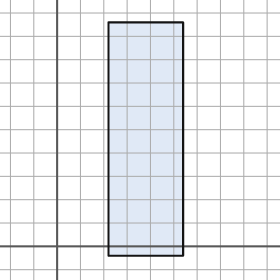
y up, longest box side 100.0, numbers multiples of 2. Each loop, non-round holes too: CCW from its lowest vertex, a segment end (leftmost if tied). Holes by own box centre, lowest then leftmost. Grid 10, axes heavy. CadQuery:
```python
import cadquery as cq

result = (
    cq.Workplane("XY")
    .moveTo(22.0, -4.0)
    .lineTo(54.0, -4.0)
    .lineTo(54.0, 96.0)
    .lineTo(22.0, 96.0)
    .close()
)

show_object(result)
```